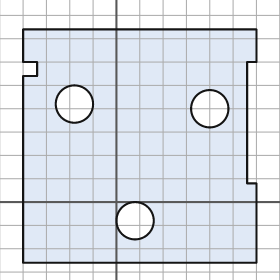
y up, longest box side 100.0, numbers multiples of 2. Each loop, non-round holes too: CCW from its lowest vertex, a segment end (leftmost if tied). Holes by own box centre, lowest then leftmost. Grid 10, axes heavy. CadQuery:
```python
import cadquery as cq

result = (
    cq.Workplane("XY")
    .moveTo(-40.0, -26.0)
    .lineTo(60.0, -26.0)
    .lineTo(60.0, 8.0)
    .lineTo(56.0, 8.0)
    .lineTo(56.0, 60.0)
    .lineTo(60.0, 60.0)
    .lineTo(60.0, 74.0)
    .lineTo(-40.0, 74.0)
    .lineTo(-40.0, 60.0)
    .lineTo(-34.0, 60.0)
    .lineTo(-34.0, 54.0)
    .lineTo(-40.0, 54.0)
    .close()
    .moveTo(8.0, -8.0)
    .circle(8.0)
    .moveTo(40.0, 40.0)
    .circle(8.0)
    .moveTo(-18.0, 42.0)
    .circle(8.0)
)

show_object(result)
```